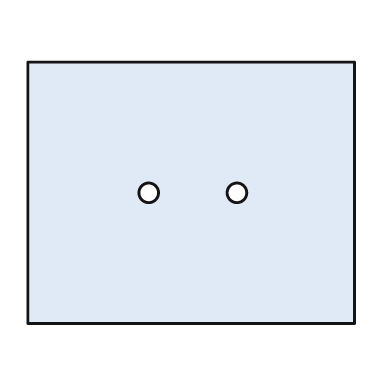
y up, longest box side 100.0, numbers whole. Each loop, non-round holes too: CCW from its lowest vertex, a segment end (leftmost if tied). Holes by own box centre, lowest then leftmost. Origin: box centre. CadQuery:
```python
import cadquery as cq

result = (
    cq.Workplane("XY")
    .moveTo(-50.0, -40.0)
    .lineTo(50.0, -40.0)
    .lineTo(50.0, 40.0)
    .lineTo(-50.0, 40.0)
    .close()
    .moveTo(-13.0, 0.0)
    .circle(3.0)
    .moveTo(14.0, 0.0)
    .circle(3.0)
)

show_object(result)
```